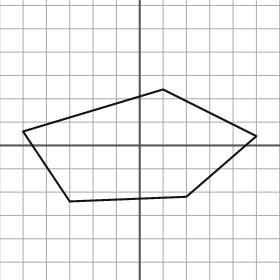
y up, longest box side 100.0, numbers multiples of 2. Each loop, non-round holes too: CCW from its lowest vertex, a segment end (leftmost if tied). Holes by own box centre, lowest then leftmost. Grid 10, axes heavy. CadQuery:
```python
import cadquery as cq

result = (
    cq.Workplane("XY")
    .moveTo(-30.0, -24.0)
    .lineTo(20.0, -22.0)
    .lineTo(50.0, 4.0)
    .lineTo(10.0, 24.0)
    .lineTo(-50.0, 6.0)
    .close()
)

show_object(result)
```